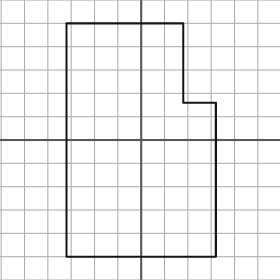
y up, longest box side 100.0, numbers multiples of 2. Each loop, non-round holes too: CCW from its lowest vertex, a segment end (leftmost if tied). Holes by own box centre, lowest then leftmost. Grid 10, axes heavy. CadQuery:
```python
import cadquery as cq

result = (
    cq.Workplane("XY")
    .moveTo(-32.0, -50.0)
    .lineTo(32.0, -50.0)
    .lineTo(32.0, 16.0)
    .lineTo(18.0, 16.0)
    .lineTo(18.0, 50.0)
    .lineTo(-32.0, 50.0)
    .close()
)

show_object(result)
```